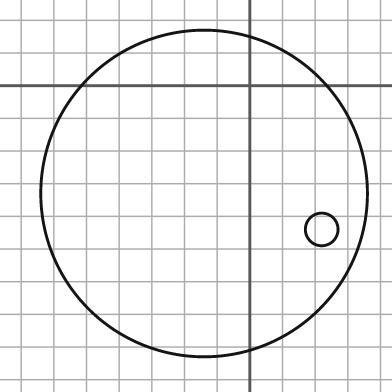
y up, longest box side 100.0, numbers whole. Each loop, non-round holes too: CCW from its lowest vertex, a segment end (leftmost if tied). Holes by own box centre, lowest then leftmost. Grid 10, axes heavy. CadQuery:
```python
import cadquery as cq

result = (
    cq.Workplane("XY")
    .moveTo(-14.0, -33.0)
    .circle(50.0)
    .moveTo(22.0, -44.0)
    .circle(5.0)
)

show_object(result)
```